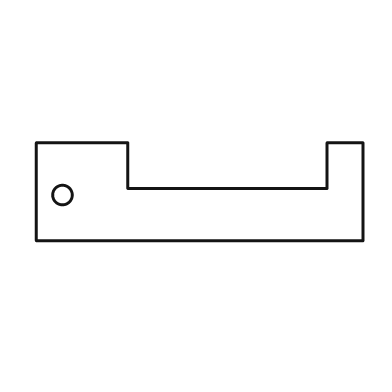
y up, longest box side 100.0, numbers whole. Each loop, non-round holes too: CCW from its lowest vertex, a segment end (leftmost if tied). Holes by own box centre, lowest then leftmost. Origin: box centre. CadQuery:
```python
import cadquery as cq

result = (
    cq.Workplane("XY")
    .moveTo(-50.0, -15.0)
    .lineTo(50.0, -15.0)
    .lineTo(50.0, 15.0)
    .lineTo(39.0, 15.0)
    .lineTo(39.0, 1.0)
    .lineTo(-22.0, 1.0)
    .lineTo(-22.0, 15.0)
    .lineTo(-50.0, 15.0)
    .close()
    .moveTo(-42.0, -1.0)
    .circle(3.0)
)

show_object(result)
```